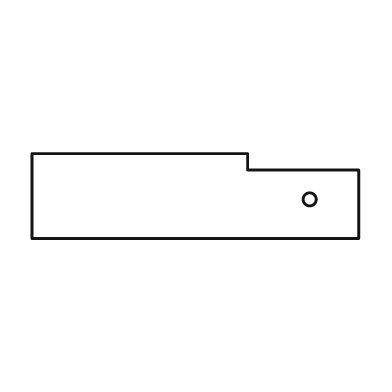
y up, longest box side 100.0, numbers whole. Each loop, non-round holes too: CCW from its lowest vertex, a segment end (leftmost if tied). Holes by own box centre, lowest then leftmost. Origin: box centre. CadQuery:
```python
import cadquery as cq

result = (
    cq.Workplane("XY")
    .moveTo(-50.0, -13.0)
    .lineTo(50.0, -13.0)
    .lineTo(50.0, 8.0)
    .lineTo(16.0, 8.0)
    .lineTo(16.0, 13.0)
    .lineTo(-50.0, 13.0)
    .close()
    .moveTo(35.0, -1.0)
    .circle(2.0)
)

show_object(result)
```